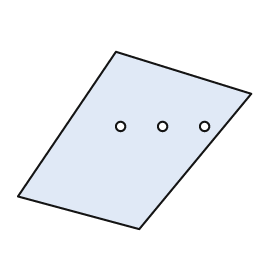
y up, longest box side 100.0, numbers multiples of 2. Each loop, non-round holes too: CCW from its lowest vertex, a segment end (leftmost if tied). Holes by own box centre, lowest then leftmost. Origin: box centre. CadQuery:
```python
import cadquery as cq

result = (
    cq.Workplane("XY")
    .moveTo(2.0, -38.0)
    .lineTo(50.0, 20.0)
    .lineTo(-8.0, 38.0)
    .lineTo(-50.0, -24.0)
    .close()
    .moveTo(-6.0, 6.0)
    .circle(2.0)
    .moveTo(12.0, 6.0)
    .circle(2.0)
    .moveTo(30.0, 6.0)
    .circle(2.0)
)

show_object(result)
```